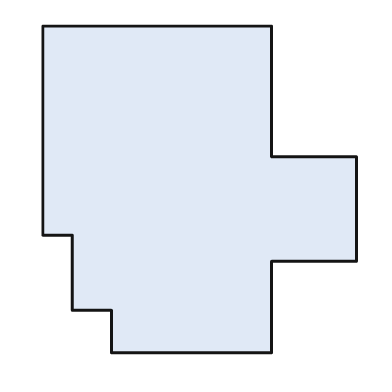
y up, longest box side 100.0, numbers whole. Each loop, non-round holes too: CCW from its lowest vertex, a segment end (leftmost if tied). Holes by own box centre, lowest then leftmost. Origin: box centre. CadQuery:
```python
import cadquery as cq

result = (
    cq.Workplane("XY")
    .moveTo(-27.0, -50.0)
    .lineTo(22.0, -50.0)
    .lineTo(22.0, -22.0)
    .lineTo(48.0, -22.0)
    .lineTo(48.0, 10.0)
    .lineTo(22.0, 10.0)
    .lineTo(22.0, 50.0)
    .lineTo(-48.0, 50.0)
    .lineTo(-48.0, -14.0)
    .lineTo(-39.0, -14.0)
    .lineTo(-39.0, -37.0)
    .lineTo(-27.0, -37.0)
    .close()
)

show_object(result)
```